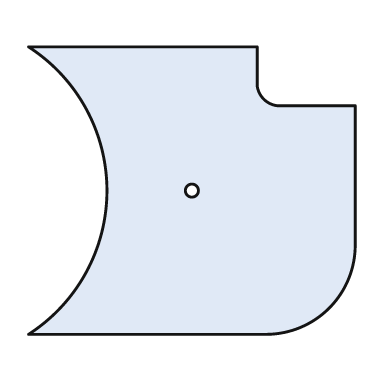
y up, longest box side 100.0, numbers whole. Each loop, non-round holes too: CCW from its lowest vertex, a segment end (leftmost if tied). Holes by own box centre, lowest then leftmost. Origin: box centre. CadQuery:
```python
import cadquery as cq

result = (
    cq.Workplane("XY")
    .moveTo(-50.0, -44.0)
    .lineTo(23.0, -44.0)
    .threePointArc((42.0, -36.0), (50.0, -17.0))
    .lineTo(50.0, 26.0)
    .lineTo(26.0, 26.0)
    .threePointArc((22.0, 28.0), (20.0, 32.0))
    .lineTo(20.0, 44.0)
    .lineTo(-50.0, 44.0)
    .threePointArc((-26.0, 0.0), (-50.0, -44.0))
    .close()
    .moveTo(0.0, 0.0)
    .circle(2.0)
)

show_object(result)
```